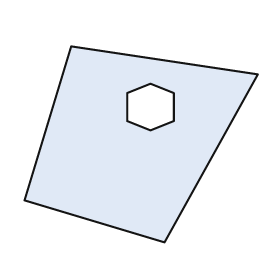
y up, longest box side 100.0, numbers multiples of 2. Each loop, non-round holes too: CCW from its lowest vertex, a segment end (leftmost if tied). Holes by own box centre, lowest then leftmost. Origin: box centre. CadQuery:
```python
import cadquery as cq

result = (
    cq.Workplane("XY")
    .moveTo(10.0, -42.0)
    .lineTo(50.0, 30.0)
    .lineTo(-30.0, 42.0)
    .lineTo(-50.0, -24.0)
    .close()
    .moveTo(4.0, 6.0)
    .lineTo(14.0, 10.0)
    .lineTo(14.0, 22.0)
    .lineTo(4.0, 26.0)
    .lineTo(-6.0, 22.0)
    .lineTo(-6.0, 10.0)
    .close()
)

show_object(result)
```